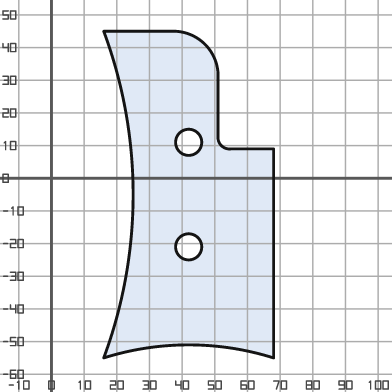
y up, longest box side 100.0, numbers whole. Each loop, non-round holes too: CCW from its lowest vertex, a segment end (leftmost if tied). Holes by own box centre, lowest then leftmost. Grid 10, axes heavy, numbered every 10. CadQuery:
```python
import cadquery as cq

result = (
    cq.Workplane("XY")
    .moveTo(16.0, -55.0)
    .threePointArc((42.0, -51.0), (68.0, -55.0))
    .lineTo(68.0, 9.0)
    .lineTo(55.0, 9.0)
    .threePointArc((52.0, 10.0), (51.0, 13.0))
    .lineTo(51.0, 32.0)
    .threePointArc((47.0, 41.0), (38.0, 45.0))
    .lineTo(16.0, 45.0)
    .threePointArc((25.0, -5.0), (16.0, -55.0))
    .close()
    .moveTo(42.0, -21.0)
    .circle(4.0)
    .moveTo(42.0, 11.0)
    .circle(4.0)
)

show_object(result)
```